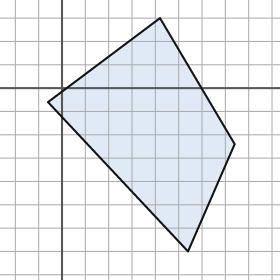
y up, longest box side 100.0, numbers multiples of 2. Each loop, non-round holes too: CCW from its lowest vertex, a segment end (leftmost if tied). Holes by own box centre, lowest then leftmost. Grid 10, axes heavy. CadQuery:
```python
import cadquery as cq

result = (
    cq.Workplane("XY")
    .moveTo(54.0, -70.0)
    .lineTo(74.0, -24.0)
    .lineTo(42.0, 30.0)
    .lineTo(-6.0, -6.0)
    .close()
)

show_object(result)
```